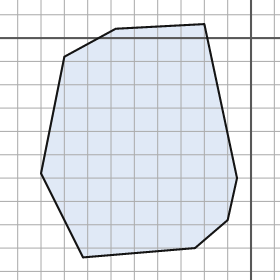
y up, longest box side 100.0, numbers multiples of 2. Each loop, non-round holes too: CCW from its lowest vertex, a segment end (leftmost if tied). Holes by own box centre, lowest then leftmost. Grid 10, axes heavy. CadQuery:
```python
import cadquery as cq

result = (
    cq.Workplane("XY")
    .moveTo(-72.0, -94.0)
    .lineTo(-24.0, -90.0)
    .lineTo(-10.0, -78.0)
    .lineTo(-6.0, -60.0)
    .lineTo(-20.0, 6.0)
    .lineTo(-58.0, 4.0)
    .lineTo(-80.0, -8.0)
    .lineTo(-90.0, -58.0)
    .close()
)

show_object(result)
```